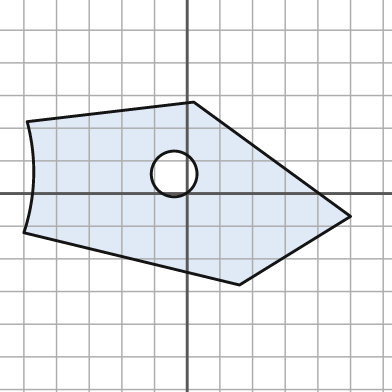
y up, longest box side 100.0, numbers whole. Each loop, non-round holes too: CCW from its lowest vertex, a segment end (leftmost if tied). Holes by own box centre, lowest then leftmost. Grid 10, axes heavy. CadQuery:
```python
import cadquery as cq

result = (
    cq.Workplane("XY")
    .moveTo(16.0, -28.0)
    .lineTo(50.0, -7.0)
    .lineTo(2.0, 28.0)
    .lineTo(-49.0, 22.0)
    .threePointArc((-47.0, 5.0), (-50.0, -12.0))
    .close()
    .moveTo(-4.0, 6.0)
    .circle(7.0)
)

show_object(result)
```